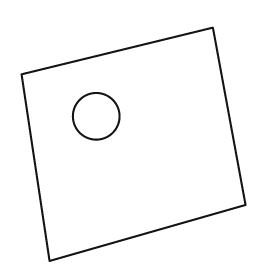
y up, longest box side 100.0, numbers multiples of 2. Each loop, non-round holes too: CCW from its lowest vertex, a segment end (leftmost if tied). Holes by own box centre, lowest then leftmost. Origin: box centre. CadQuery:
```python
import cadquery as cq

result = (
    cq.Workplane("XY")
    .moveTo(-36.0, -50.0)
    .lineTo(48.0, -26.0)
    .lineTo(34.0, 50.0)
    .lineTo(-48.0, 30.0)
    .close()
    .moveTo(-16.0, 12.0)
    .circle(10.0)
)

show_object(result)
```